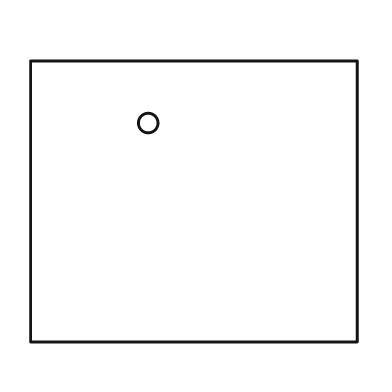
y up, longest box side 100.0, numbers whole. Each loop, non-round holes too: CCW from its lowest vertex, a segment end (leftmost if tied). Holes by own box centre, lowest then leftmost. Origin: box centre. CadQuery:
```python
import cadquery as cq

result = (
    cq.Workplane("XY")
    .moveTo(-50.0, -43.0)
    .lineTo(50.0, -43.0)
    .lineTo(50.0, 43.0)
    .lineTo(-50.0, 43.0)
    .close()
    .moveTo(-14.0, 24.0)
    .circle(3.0)
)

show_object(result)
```